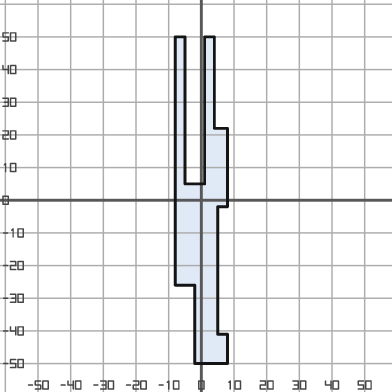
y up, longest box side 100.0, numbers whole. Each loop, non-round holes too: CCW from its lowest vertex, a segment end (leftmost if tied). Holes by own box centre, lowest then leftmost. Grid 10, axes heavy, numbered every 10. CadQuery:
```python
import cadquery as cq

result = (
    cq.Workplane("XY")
    .moveTo(-2.0, -50.0)
    .lineTo(8.0, -50.0)
    .lineTo(8.0, -41.0)
    .lineTo(5.0, -41.0)
    .lineTo(5.0, -2.0)
    .lineTo(8.0, -2.0)
    .lineTo(8.0, 22.0)
    .lineTo(4.0, 22.0)
    .lineTo(4.0, 50.0)
    .lineTo(1.0, 50.0)
    .lineTo(1.0, 5.0)
    .lineTo(-5.0, 5.0)
    .lineTo(-5.0, 50.0)
    .lineTo(-8.0, 50.0)
    .lineTo(-8.0, -26.0)
    .lineTo(-2.0, -26.0)
    .close()
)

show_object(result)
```